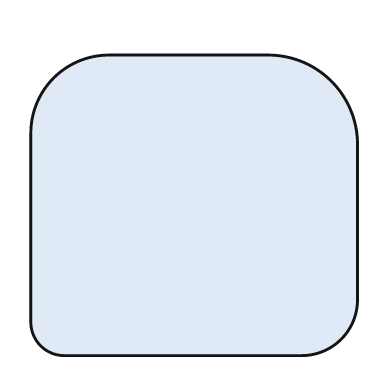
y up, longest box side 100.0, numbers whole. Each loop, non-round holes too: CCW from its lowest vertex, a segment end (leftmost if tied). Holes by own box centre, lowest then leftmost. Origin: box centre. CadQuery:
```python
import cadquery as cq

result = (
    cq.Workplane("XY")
    .moveTo(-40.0, -46.0)
    .lineTo(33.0, -46.0)
    .threePointArc((45.0, -41.0), (50.0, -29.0))
    .lineTo(50.0, 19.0)
    .threePointArc((42.0, 38.0), (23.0, 46.0))
    .lineTo(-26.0, 46.0)
    .threePointArc((-43.0, 39.0), (-50.0, 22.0))
    .lineTo(-50.0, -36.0)
    .threePointArc((-47.0, -43.0), (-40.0, -46.0))
    .close()
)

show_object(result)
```